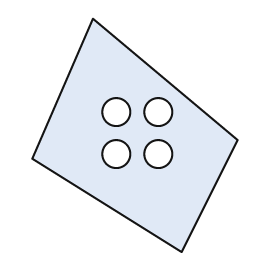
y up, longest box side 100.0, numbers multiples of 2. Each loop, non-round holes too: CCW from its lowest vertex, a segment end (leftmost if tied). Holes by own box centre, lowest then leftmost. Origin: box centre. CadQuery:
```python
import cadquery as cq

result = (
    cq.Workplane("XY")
    .moveTo(20.0, -50.0)
    .lineTo(44.0, -2.0)
    .lineTo(-18.0, 50.0)
    .lineTo(-44.0, -10.0)
    .close()
    .moveTo(-8.0, -8.0)
    .circle(6.0)
    .moveTo(10.0, -8.0)
    .circle(6.0)
    .moveTo(-8.0, 10.0)
    .circle(6.0)
    .moveTo(10.0, 10.0)
    .circle(6.0)
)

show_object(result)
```